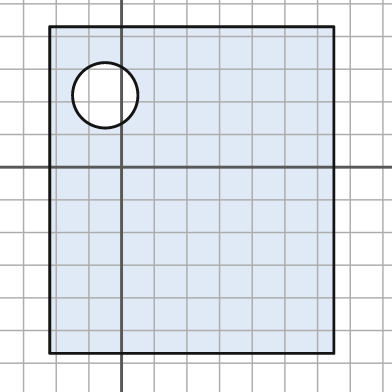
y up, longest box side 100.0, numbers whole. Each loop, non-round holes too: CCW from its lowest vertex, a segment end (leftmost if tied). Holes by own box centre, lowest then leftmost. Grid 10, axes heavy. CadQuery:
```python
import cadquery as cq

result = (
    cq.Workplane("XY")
    .moveTo(-22.0, -57.0)
    .lineTo(65.0, -57.0)
    .lineTo(65.0, 43.0)
    .lineTo(-22.0, 43.0)
    .close()
    .moveTo(-5.0, 22.0)
    .circle(10.0)
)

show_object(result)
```